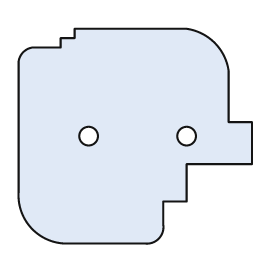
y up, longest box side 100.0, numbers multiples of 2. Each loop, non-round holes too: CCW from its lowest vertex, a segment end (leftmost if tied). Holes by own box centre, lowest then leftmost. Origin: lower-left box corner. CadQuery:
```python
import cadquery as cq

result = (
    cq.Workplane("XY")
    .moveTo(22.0, 0.0)
    .lineTo(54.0, 0.0)
    .threePointArc((60.0, 2.0), (62.0, 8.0))
    .lineTo(62.0, 18.0)
    .lineTo(72.0, 18.0)
    .lineTo(72.0, 34.0)
    .lineTo(100.0, 34.0)
    .lineTo(100.0, 52.0)
    .lineTo(90.0, 52.0)
    .lineTo(90.0, 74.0)
    .threePointArc((84.0, 86.0), (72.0, 92.0))
    .lineTo(24.0, 92.0)
    .lineTo(24.0, 88.0)
    .lineTo(18.0, 88.0)
    .lineTo(18.0, 84.0)
    .lineTo(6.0, 84.0)
    .threePointArc((2.0, 82.0), (0.0, 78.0))
    .lineTo(0.0, 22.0)
    .threePointArc((6.0, 6.0), (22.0, 0.0))
    .close()
    .moveTo(30.0, 46.0)
    .circle(4.0)
    .moveTo(72.0, 46.0)
    .circle(4.0)
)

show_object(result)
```